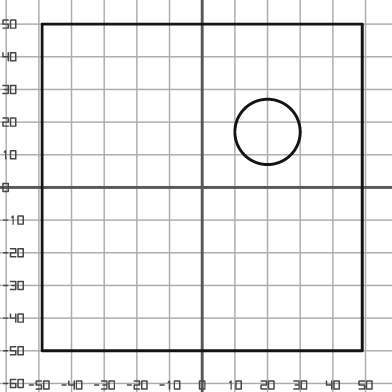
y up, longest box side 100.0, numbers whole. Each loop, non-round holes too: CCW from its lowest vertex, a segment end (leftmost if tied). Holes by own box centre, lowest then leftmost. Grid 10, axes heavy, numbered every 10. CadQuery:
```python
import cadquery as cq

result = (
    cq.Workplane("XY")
    .moveTo(-49.0, -50.0)
    .lineTo(49.0, -50.0)
    .lineTo(49.0, 50.0)
    .lineTo(-49.0, 50.0)
    .close()
    .moveTo(20.0, 17.0)
    .circle(10.0)
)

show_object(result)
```